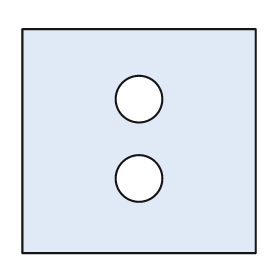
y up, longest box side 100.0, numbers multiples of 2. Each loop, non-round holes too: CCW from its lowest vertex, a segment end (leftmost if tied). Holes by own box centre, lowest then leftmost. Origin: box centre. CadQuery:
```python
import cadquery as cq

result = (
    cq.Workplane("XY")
    .moveTo(-50.0, -48.0)
    .lineTo(50.0, -48.0)
    .lineTo(50.0, 48.0)
    .lineTo(-50.0, 48.0)
    .close()
    .moveTo(0.0, -16.0)
    .circle(10.0)
    .moveTo(0.0, 18.0)
    .circle(10.0)
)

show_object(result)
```